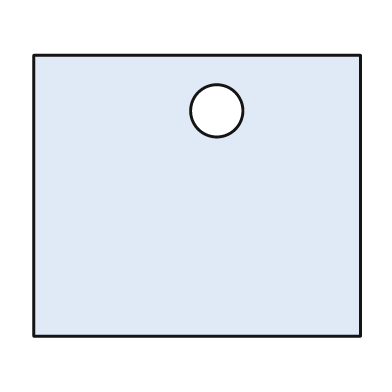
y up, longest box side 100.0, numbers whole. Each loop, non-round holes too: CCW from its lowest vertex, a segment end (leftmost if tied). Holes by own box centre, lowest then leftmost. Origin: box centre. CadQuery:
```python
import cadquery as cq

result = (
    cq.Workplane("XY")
    .moveTo(-50.0, -43.0)
    .lineTo(50.0, -43.0)
    .lineTo(50.0, 43.0)
    .lineTo(-50.0, 43.0)
    .close()
    .moveTo(6.0, 26.0)
    .circle(8.0)
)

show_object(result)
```